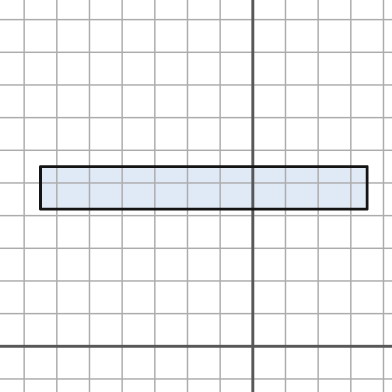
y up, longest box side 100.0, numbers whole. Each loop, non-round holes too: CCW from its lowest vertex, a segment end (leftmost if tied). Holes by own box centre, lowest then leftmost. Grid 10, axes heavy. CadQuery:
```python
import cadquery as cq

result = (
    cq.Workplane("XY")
    .moveTo(-65.0, 42.0)
    .lineTo(35.0, 42.0)
    .lineTo(35.0, 55.0)
    .lineTo(-65.0, 55.0)
    .close()
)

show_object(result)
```